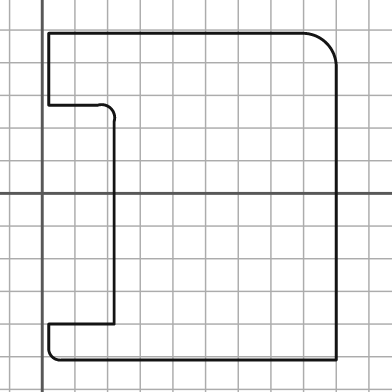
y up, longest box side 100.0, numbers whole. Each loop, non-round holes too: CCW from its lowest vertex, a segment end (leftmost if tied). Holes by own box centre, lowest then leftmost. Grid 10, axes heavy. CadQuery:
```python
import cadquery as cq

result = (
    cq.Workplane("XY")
    .moveTo(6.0, -51.0)
    .lineTo(90.0, -51.0)
    .lineTo(90.0, 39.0)
    .threePointArc((87.0, 46.0), (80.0, 49.0))
    .lineTo(2.0, 49.0)
    .lineTo(2.0, 27.0)
    .lineTo(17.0, 27.0)
    .threePointArc((21.0, 26.0), (22.0, 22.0))
    .lineTo(22.0, -40.0)
    .lineTo(2.0, -40.0)
    .lineTo(2.0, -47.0)
    .threePointArc((3.0, -50.0), (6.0, -51.0))
    .close()
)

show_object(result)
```